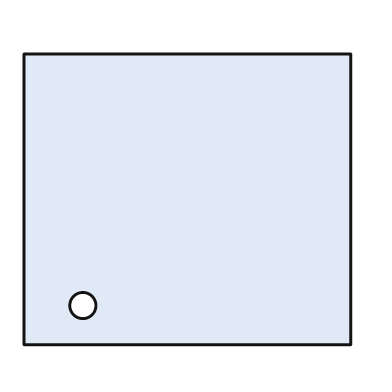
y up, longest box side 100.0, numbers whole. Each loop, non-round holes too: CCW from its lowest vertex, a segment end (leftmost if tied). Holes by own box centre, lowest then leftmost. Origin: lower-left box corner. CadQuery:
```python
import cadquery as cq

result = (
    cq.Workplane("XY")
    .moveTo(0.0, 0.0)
    .lineTo(100.0, 0.0)
    .lineTo(100.0, 89.0)
    .lineTo(0.0, 89.0)
    .close()
    .moveTo(18.0, 12.0)
    .circle(4.0)
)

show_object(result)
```